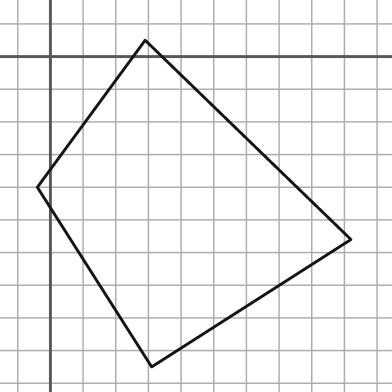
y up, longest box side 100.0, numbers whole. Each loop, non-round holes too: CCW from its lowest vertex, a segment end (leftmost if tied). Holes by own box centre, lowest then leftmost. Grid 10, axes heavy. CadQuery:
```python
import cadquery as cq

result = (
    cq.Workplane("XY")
    .moveTo(31.0, -95.0)
    .lineTo(92.0, -56.0)
    .lineTo(29.0, 5.0)
    .lineTo(-4.0, -40.0)
    .close()
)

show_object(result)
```